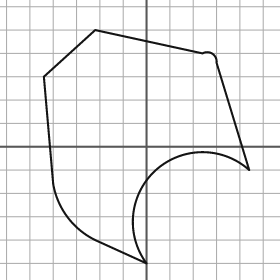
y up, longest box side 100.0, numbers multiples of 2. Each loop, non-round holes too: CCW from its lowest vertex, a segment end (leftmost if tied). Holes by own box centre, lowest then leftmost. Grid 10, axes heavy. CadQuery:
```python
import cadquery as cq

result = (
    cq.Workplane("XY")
    .moveTo(0.0, -50.0)
    .threePointArc((4.0, -10.0), (44.0, -10.0))
    .lineTo(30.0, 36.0)
    .threePointArc((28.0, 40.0), (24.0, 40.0))
    .lineTo(-22.0, 50.0)
    .lineTo(-44.0, 30.0)
    .lineTo(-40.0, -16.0)
    .threePointArc((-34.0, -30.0), (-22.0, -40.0))
    .close()
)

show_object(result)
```